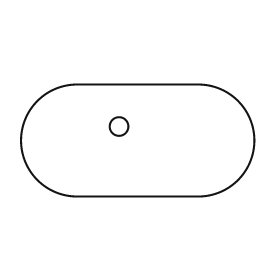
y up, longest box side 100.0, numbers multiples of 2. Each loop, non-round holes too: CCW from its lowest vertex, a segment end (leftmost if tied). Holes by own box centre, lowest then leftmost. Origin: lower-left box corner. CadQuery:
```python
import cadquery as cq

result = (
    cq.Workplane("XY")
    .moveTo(24.0, 0.0)
    .lineTo(76.0, 0.0)
    .threePointArc((100.0, 24.0), (76.0, 48.0))
    .lineTo(24.0, 48.0)
    .threePointArc((0.0, 24.0), (24.0, 0.0))
    .close()
    .moveTo(42.0, 30.0)
    .circle(4.0)
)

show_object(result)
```